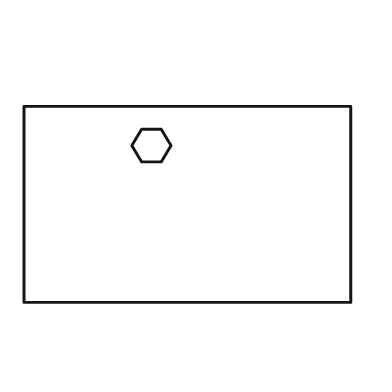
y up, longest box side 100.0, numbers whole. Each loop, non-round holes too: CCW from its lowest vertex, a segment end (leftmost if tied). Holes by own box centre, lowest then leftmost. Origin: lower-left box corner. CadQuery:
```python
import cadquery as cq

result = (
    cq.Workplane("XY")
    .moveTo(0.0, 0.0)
    .lineTo(100.0, 0.0)
    .lineTo(100.0, 60.0)
    .lineTo(0.0, 60.0)
    .close()
    .moveTo(36.0, 43.0)
    .lineTo(42.0, 43.0)
    .lineTo(45.0, 48.0)
    .lineTo(42.0, 53.0)
    .lineTo(36.0, 53.0)
    .lineTo(33.0, 48.0)
    .close()
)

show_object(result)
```